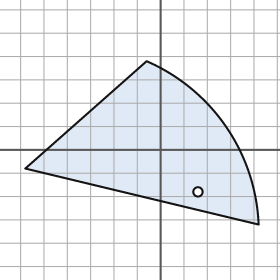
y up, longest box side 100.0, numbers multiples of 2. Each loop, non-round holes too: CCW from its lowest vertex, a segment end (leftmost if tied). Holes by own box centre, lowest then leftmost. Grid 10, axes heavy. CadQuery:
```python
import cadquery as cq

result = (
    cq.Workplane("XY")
    .moveTo(42.0, -32.0)
    .threePointArc((28.0, 10.0), (-6.0, 38.0))
    .lineTo(-58.0, -8.0)
    .close()
    .moveTo(16.0, -18.0)
    .circle(2.0)
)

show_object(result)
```